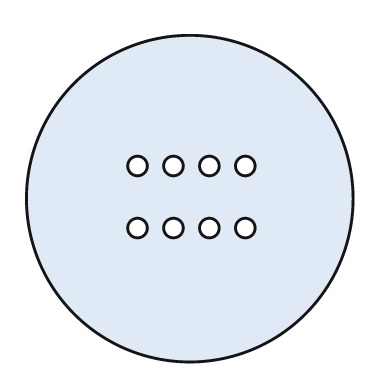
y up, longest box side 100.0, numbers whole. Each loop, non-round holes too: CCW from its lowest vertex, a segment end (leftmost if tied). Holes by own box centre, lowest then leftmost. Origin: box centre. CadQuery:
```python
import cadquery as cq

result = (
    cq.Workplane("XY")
    .moveTo(0.0, 0.0)
    .circle(50.0)
    .moveTo(-16.0, -9.0)
    .circle(3.0)
    .moveTo(-5.0, -9.0)
    .circle(3.0)
    .moveTo(6.0, -9.0)
    .circle(3.0)
    .moveTo(17.0, -9.0)
    .circle(3.0)
    .moveTo(-16.0, 10.0)
    .circle(3.0)
    .moveTo(-5.0, 10.0)
    .circle(3.0)
    .moveTo(6.0, 10.0)
    .circle(3.0)
    .moveTo(17.0, 10.0)
    .circle(3.0)
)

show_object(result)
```